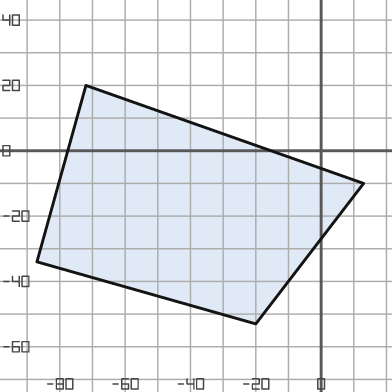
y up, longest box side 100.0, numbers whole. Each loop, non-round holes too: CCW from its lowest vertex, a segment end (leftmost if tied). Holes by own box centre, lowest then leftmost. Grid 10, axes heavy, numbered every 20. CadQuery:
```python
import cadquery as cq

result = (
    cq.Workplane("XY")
    .moveTo(-20.0, -53.0)
    .lineTo(13.0, -10.0)
    .lineTo(-72.0, 20.0)
    .lineTo(-87.0, -34.0)
    .close()
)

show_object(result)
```